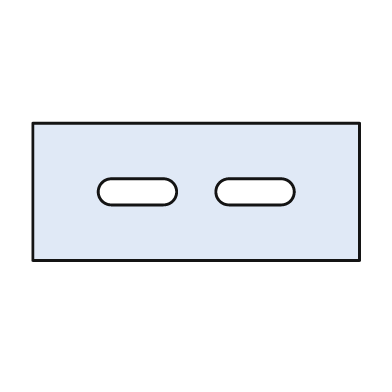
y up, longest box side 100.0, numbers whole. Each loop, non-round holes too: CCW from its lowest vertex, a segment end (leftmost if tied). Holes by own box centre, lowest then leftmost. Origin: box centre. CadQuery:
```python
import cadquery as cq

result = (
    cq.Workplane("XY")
    .moveTo(-50.0, -21.0)
    .lineTo(50.0, -21.0)
    .lineTo(50.0, 21.0)
    .lineTo(-50.0, 21.0)
    .close()
    .moveTo(-26.0, -4.0)
    .lineTo(-10.0, -4.0)
    .threePointArc((-6.0, 0.0), (-10.0, 4.0))
    .lineTo(-26.0, 4.0)
    .threePointArc((-30.0, 0.0), (-26.0, -4.0))
    .close()
    .moveTo(10.0, -4.0)
    .lineTo(26.0, -4.0)
    .threePointArc((30.0, 0.0), (26.0, 4.0))
    .lineTo(10.0, 4.0)
    .threePointArc((6.0, 0.0), (10.0, -4.0))
    .close()
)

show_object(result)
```